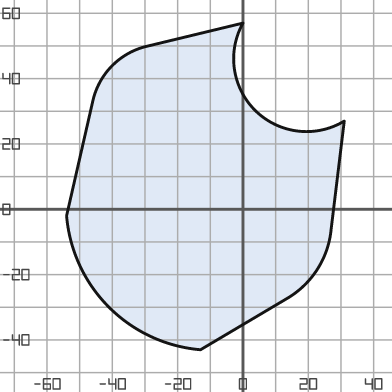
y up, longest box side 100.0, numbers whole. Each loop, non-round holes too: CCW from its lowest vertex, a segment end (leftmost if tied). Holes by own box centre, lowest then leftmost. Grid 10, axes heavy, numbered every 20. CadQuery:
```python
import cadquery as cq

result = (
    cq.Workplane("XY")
    .moveTo(-13.0, -43.0)
    .lineTo(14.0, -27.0)
    .threePointArc((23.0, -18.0), (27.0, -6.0))
    .lineTo(31.0, 27.0)
    .threePointArc((4.0, 30.0), (0.0, 57.0))
    .lineTo(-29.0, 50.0)
    .threePointArc((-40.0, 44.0), (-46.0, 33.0))
    .lineTo(-54.0, -2.0)
    .threePointArc((-41.0, -30.0), (-13.0, -43.0))
    .close()
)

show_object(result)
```